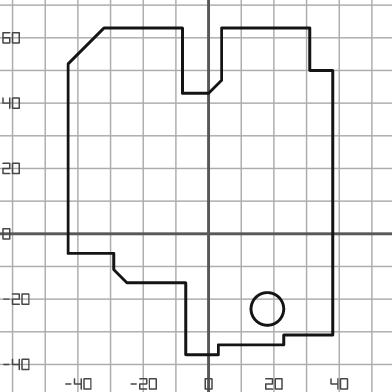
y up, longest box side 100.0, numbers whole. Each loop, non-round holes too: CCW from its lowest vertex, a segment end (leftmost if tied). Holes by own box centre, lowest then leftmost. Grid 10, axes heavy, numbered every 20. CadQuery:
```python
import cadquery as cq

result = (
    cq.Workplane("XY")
    .moveTo(-7.0, -37.0)
    .lineTo(3.0, -37.0)
    .lineTo(3.0, -34.0)
    .lineTo(23.0, -34.0)
    .lineTo(23.0, -31.0)
    .lineTo(38.0, -31.0)
    .lineTo(38.0, 50.0)
    .lineTo(31.0, 50.0)
    .lineTo(31.0, 63.0)
    .lineTo(4.0, 63.0)
    .lineTo(4.0, 47.0)
    .lineTo(0.0, 43.0)
    .lineTo(-8.0, 43.0)
    .lineTo(-8.0, 63.0)
    .lineTo(-32.0, 63.0)
    .lineTo(-43.0, 52.0)
    .lineTo(-43.0, -6.0)
    .lineTo(-29.0, -6.0)
    .lineTo(-29.0, -11.0)
    .lineTo(-25.0, -15.0)
    .lineTo(-7.0, -15.0)
    .close()
    .moveTo(18.0, -23.0)
    .circle(5.0)
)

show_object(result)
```